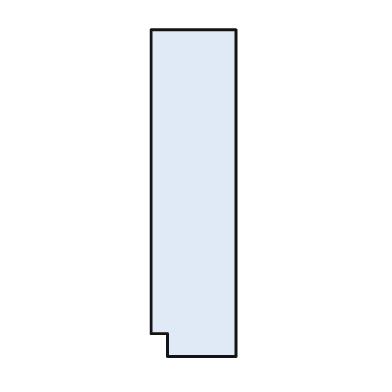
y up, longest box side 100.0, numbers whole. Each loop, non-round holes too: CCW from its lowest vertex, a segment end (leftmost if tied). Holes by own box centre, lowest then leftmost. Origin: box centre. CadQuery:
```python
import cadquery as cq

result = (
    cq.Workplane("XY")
    .moveTo(-8.0, -50.0)
    .lineTo(13.0, -50.0)
    .lineTo(13.0, 50.0)
    .lineTo(-13.0, 50.0)
    .lineTo(-13.0, -43.0)
    .lineTo(-8.0, -43.0)
    .close()
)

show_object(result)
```